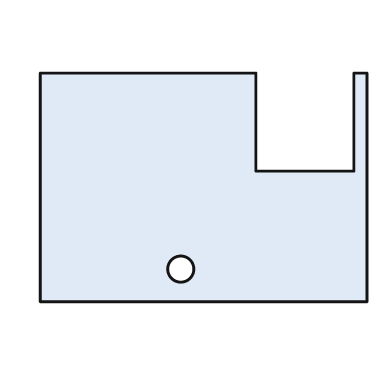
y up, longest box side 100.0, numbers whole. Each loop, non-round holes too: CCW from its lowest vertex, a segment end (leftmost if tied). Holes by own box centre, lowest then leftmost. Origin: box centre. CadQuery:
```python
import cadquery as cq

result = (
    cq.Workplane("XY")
    .moveTo(-50.0, -35.0)
    .lineTo(50.0, -35.0)
    .lineTo(50.0, 35.0)
    .lineTo(46.0, 35.0)
    .lineTo(46.0, 5.0)
    .lineTo(16.0, 5.0)
    .lineTo(16.0, 35.0)
    .lineTo(-50.0, 35.0)
    .close()
    .moveTo(-7.0, -25.0)
    .circle(4.0)
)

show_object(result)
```